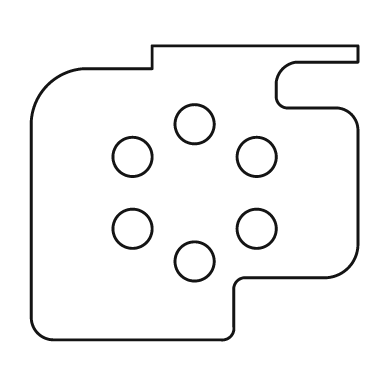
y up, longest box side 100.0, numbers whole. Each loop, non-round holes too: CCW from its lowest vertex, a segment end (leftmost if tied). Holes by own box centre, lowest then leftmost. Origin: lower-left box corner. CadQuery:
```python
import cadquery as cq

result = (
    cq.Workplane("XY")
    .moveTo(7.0, 0.0)
    .lineTo(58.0, 0.0)
    .threePointArc((61.0, 1.0), (62.0, 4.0))
    .lineTo(62.0, 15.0)
    .threePointArc((63.0, 18.0), (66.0, 19.0))
    .lineTo(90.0, 19.0)
    .threePointArc((97.0, 22.0), (100.0, 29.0))
    .lineTo(100.0, 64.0)
    .threePointArc((98.0, 69.0), (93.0, 71.0))
    .lineTo(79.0, 71.0)
    .threePointArc((76.0, 72.0), (75.0, 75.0))
    .lineTo(75.0, 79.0)
    .threePointArc((77.0, 83.0), (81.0, 85.0))
    .lineTo(100.0, 85.0)
    .lineTo(100.0, 90.0)
    .lineTo(37.0, 90.0)
    .lineTo(37.0, 83.0)
    .lineTo(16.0, 83.0)
    .threePointArc((5.0, 78.0), (0.0, 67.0))
    .lineTo(0.0, 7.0)
    .threePointArc((2.0, 2.0), (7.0, 0.0))
    .close()
    .moveTo(50.0, 24.0)
    .circle(6.0)
    .moveTo(31.0, 34.0)
    .circle(6.0)
    .moveTo(69.0, 34.0)
    .circle(6.0)
    .moveTo(31.0, 56.0)
    .circle(6.0)
    .moveTo(69.0, 56.0)
    .circle(6.0)
    .moveTo(50.0, 66.0)
    .circle(6.0)
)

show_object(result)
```